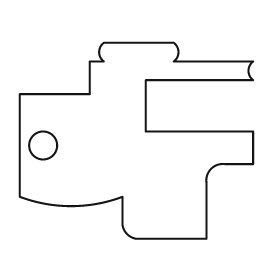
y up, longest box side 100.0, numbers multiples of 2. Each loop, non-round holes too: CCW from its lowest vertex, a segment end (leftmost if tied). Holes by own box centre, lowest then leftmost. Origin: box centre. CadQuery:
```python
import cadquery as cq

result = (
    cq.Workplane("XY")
    .moveTo(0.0, -42.0)
    .lineTo(30.0, -42.0)
    .lineTo(30.0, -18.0)
    .threePointArc((32.0, -12.0), (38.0, -10.0))
    .lineTo(50.0, -10.0)
    .lineTo(50.0, 4.0)
    .lineTo(4.0, 4.0)
    .lineTo(4.0, 26.0)
    .lineTo(50.0, 26.0)
    .threePointArc((48.0, 30.0), (50.0, 34.0))
    .lineTo(16.0, 34.0)
    .threePointArc((18.0, 38.0), (16.0, 42.0))
    .lineTo(-14.0, 42.0)
    .threePointArc((-16.0, 38.0), (-14.0, 34.0))
    .lineTo(-20.0, 34.0)
    .lineTo(-20.0, 20.0)
    .lineTo(-50.0, 20.0)
    .lineTo(-50.0, -24.0)
    .threePointArc((-28.0, -28.0), (-6.0, -24.0))
    .lineTo(-6.0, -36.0)
    .threePointArc((-4.0, -40.0), (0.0, -42.0))
    .close()
    .moveTo(-40.0, -2.0)
    .circle(6.0)
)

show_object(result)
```